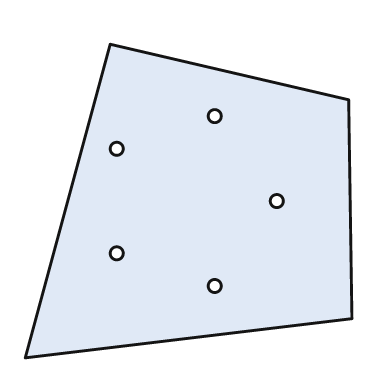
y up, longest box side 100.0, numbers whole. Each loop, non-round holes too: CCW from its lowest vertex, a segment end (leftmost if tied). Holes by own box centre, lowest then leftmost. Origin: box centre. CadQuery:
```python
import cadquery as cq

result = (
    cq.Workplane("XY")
    .moveTo(-50.0, -48.0)
    .lineTo(50.0, -36.0)
    .lineTo(49.0, 31.0)
    .lineTo(-24.0, 48.0)
    .close()
    .moveTo(8.0, -26.0)
    .circle(2.0)
    .moveTo(-22.0, -16.0)
    .circle(2.0)
    .moveTo(27.0, 0.0)
    .circle(2.0)
    .moveTo(-22.0, 16.0)
    .circle(2.0)
    .moveTo(8.0, 26.0)
    .circle(2.0)
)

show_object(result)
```